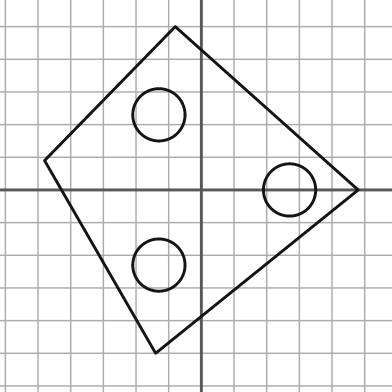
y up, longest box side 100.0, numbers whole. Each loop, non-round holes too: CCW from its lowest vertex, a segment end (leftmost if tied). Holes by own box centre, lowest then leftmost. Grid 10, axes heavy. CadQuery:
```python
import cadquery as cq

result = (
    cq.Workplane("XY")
    .moveTo(-14.0, -50.0)
    .lineTo(48.0, 0.0)
    .lineTo(-8.0, 50.0)
    .lineTo(-48.0, 9.0)
    .close()
    .moveTo(-13.0, -23.0)
    .circle(8.0)
    .moveTo(27.0, 0.0)
    .circle(8.0)
    .moveTo(-13.0, 23.0)
    .circle(8.0)
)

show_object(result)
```